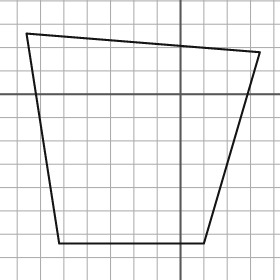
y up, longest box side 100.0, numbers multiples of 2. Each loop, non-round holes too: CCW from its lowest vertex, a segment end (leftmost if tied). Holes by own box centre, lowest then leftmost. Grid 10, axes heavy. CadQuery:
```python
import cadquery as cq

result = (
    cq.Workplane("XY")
    .moveTo(-52.0, -64.0)
    .lineTo(10.0, -64.0)
    .lineTo(34.0, 18.0)
    .lineTo(-66.0, 26.0)
    .close()
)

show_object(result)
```